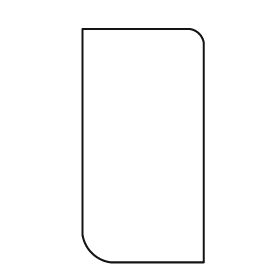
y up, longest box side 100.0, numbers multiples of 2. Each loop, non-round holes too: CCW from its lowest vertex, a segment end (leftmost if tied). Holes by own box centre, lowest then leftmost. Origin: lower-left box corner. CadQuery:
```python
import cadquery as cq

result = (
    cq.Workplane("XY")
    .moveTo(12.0, 0.0)
    .lineTo(52.0, 0.0)
    .lineTo(52.0, 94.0)
    .threePointArc((50.0, 98.0), (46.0, 100.0))
    .lineTo(0.0, 100.0)
    .lineTo(0.0, 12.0)
    .threePointArc((4.0, 4.0), (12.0, 0.0))
    .close()
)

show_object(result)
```